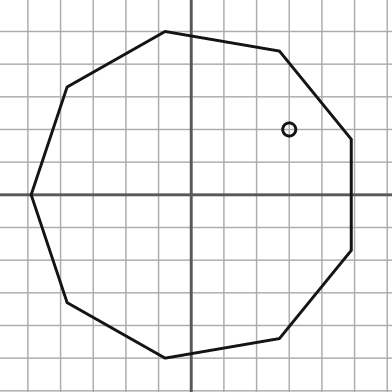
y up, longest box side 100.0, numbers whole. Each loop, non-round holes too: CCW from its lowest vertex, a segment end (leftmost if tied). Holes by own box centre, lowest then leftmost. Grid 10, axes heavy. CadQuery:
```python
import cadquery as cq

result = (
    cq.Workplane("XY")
    .moveTo(-8.0, -50.0)
    .lineTo(27.0, -44.0)
    .lineTo(49.0, -17.0)
    .lineTo(49.0, 17.0)
    .lineTo(27.0, 44.0)
    .lineTo(-8.0, 50.0)
    .lineTo(-38.0, 33.0)
    .lineTo(-49.0, 0.0)
    .lineTo(-38.0, -33.0)
    .close()
    .moveTo(30.0, 20.0)
    .circle(2.0)
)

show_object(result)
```